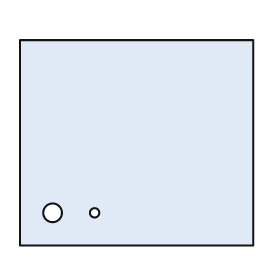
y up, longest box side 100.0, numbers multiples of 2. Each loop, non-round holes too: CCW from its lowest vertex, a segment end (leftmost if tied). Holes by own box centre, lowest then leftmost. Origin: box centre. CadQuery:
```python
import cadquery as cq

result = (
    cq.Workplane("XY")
    .moveTo(-50.0, -44.0)
    .lineTo(50.0, -44.0)
    .lineTo(50.0, 44.0)
    .lineTo(-50.0, 44.0)
    .close()
    .moveTo(-36.0, -30.0)
    .circle(4.0)
    .moveTo(-18.0, -30.0)
    .circle(2.0)
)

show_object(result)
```